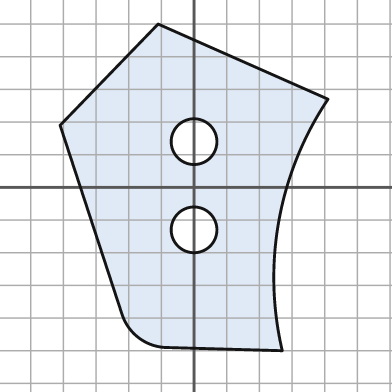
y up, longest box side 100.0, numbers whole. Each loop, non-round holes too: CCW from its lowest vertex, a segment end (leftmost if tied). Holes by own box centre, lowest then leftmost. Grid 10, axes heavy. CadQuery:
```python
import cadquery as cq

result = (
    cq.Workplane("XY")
    .moveTo(27.0, -50.0)
    .threePointArc((26.0, -10.0), (41.0, 27.0))
    .lineTo(-11.0, 50.0)
    .lineTo(-41.0, 19.0)
    .lineTo(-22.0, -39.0)
    .threePointArc((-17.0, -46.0), (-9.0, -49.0))
    .close()
    .moveTo(0.0, -13.0)
    .circle(7.0)
    .moveTo(0.0, 14.0)
    .circle(7.0)
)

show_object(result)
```